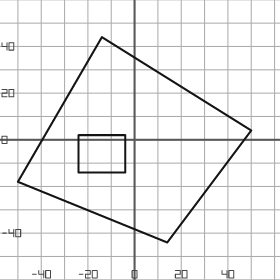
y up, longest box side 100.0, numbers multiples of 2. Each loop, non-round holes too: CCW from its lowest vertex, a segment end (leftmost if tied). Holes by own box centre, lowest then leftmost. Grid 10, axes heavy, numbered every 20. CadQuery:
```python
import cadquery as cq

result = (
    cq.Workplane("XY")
    .moveTo(14.0, -44.0)
    .lineTo(50.0, 4.0)
    .lineTo(-14.0, 44.0)
    .lineTo(-50.0, -18.0)
    .close()
    .moveTo(-24.0, -14.0)
    .lineTo(-4.0, -14.0)
    .lineTo(-4.0, 2.0)
    .lineTo(-24.0, 2.0)
    .close()
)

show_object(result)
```